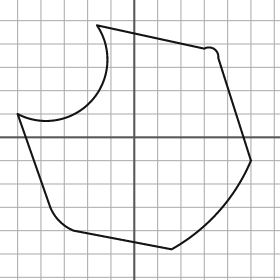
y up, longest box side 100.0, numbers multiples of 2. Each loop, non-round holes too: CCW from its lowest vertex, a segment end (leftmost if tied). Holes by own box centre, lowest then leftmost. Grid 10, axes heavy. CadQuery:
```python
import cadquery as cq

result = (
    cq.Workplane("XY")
    .moveTo(16.0, -48.0)
    .threePointArc((36.0, -32.0), (50.0, -10.0))
    .lineTo(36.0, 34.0)
    .threePointArc((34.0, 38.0), (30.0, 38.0))
    .lineTo(-16.0, 48.0)
    .threePointArc((-18.0, 16.0), (-50.0, 10.0))
    .lineTo(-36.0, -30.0)
    .threePointArc((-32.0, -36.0), (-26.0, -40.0))
    .close()
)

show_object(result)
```